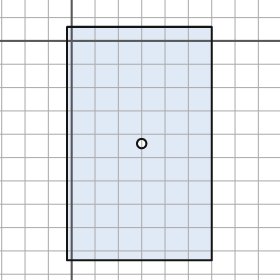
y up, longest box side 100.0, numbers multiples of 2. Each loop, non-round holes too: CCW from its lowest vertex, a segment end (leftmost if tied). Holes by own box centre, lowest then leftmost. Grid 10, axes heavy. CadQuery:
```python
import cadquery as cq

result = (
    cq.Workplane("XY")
    .moveTo(-2.0, -94.0)
    .lineTo(60.0, -94.0)
    .lineTo(60.0, 6.0)
    .lineTo(-2.0, 6.0)
    .close()
    .moveTo(30.0, -44.0)
    .circle(2.0)
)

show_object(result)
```